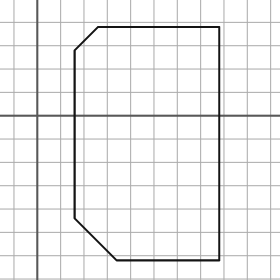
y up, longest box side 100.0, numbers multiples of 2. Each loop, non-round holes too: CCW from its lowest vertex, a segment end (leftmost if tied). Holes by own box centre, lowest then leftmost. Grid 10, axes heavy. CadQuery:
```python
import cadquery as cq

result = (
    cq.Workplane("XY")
    .moveTo(34.0, -62.0)
    .lineTo(78.0, -62.0)
    .lineTo(78.0, 38.0)
    .lineTo(26.0, 38.0)
    .lineTo(16.0, 28.0)
    .lineTo(16.0, -44.0)
    .close()
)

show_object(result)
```